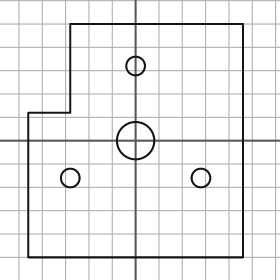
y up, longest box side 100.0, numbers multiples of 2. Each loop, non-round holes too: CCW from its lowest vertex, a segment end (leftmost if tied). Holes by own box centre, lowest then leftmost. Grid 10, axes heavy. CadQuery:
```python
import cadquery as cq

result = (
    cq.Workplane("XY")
    .moveTo(-46.0, -50.0)
    .lineTo(46.0, -50.0)
    .lineTo(46.0, 50.0)
    .lineTo(-28.0, 50.0)
    .lineTo(-28.0, 12.0)
    .lineTo(-46.0, 12.0)
    .close()
    .moveTo(-28.0, -16.0)
    .circle(4.0)
    .moveTo(28.0, -16.0)
    .circle(4.0)
    .moveTo(0.0, 0.0)
    .circle(8.0)
    .moveTo(0.0, 32.0)
    .circle(4.0)
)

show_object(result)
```